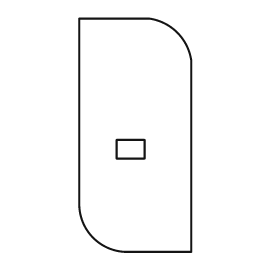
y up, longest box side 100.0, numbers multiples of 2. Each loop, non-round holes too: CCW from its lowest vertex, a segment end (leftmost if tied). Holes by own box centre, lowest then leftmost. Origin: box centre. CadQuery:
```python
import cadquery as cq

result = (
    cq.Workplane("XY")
    .moveTo(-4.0, -50.0)
    .lineTo(24.0, -50.0)
    .lineTo(24.0, 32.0)
    .threePointArc((18.0, 44.0), (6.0, 50.0))
    .lineTo(-24.0, 50.0)
    .lineTo(-24.0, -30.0)
    .threePointArc((-18.0, -44.0), (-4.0, -50.0))
    .close()
    .moveTo(-8.0, -10.0)
    .lineTo(4.0, -10.0)
    .lineTo(4.0, -2.0)
    .lineTo(-8.0, -2.0)
    .close()
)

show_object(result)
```